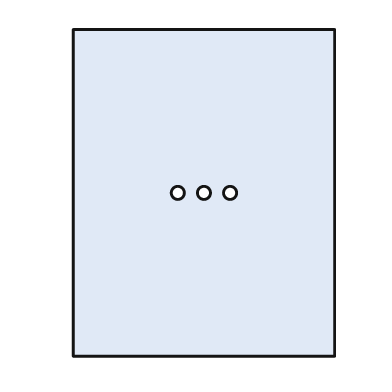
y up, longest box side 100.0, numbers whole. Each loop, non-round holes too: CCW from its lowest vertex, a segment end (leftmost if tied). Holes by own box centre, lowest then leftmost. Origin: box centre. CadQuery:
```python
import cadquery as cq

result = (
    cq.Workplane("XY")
    .moveTo(-40.0, -50.0)
    .lineTo(40.0, -50.0)
    .lineTo(40.0, 50.0)
    .lineTo(-40.0, 50.0)
    .close()
    .moveTo(-8.0, 0.0)
    .circle(2.0)
    .moveTo(0.0, 0.0)
    .circle(2.0)
    .moveTo(8.0, 0.0)
    .circle(2.0)
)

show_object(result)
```